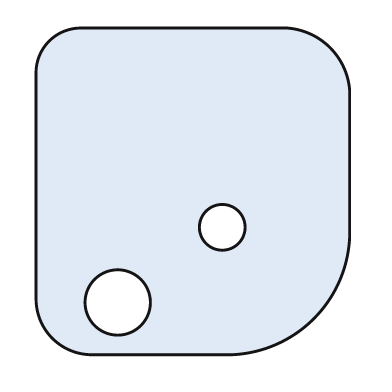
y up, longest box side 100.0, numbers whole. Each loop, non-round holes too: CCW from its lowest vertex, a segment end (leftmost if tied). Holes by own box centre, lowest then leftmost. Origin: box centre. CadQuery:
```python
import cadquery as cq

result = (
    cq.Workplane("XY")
    .moveTo(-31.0, -50.0)
    .lineTo(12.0, -50.0)
    .threePointArc((37.0, -39.0), (48.0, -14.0))
    .lineTo(48.0, 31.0)
    .threePointArc((42.0, 44.0), (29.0, 50.0))
    .lineTo(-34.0, 50.0)
    .threePointArc((-44.0, 46.0), (-48.0, 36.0))
    .lineTo(-48.0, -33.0)
    .threePointArc((-43.0, -45.0), (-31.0, -50.0))
    .close()
    .moveTo(-23.0, -34.0)
    .circle(10.0)
    .moveTo(9.0, -11.0)
    .circle(7.0)
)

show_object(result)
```